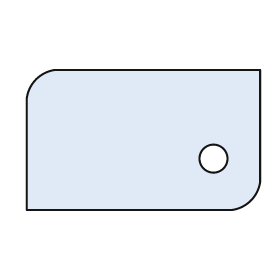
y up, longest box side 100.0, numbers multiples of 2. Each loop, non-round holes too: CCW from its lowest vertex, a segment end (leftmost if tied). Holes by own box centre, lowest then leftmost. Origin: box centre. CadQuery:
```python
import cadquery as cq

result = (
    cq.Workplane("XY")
    .moveTo(-50.0, -30.0)
    .lineTo(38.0, -30.0)
    .threePointArc((46.0, -26.0), (50.0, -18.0))
    .lineTo(50.0, 30.0)
    .lineTo(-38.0, 30.0)
    .threePointArc((-46.0, 26.0), (-50.0, 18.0))
    .close()
    .moveTo(30.0, -8.0)
    .circle(6.0)
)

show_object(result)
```